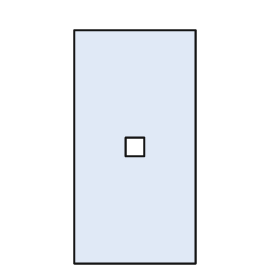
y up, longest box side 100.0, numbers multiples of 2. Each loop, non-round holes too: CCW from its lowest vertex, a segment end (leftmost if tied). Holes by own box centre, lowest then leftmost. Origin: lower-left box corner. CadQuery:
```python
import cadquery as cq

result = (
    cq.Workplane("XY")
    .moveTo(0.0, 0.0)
    .lineTo(52.0, 0.0)
    .lineTo(52.0, 100.0)
    .lineTo(0.0, 100.0)
    .close()
    .moveTo(22.0, 46.0)
    .lineTo(30.0, 46.0)
    .lineTo(30.0, 54.0)
    .lineTo(22.0, 54.0)
    .close()
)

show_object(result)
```